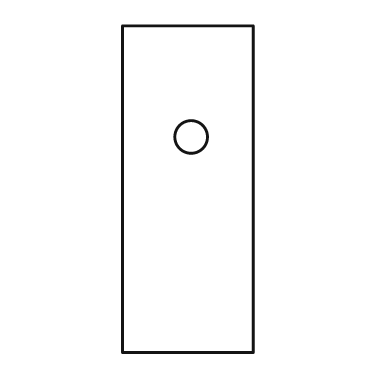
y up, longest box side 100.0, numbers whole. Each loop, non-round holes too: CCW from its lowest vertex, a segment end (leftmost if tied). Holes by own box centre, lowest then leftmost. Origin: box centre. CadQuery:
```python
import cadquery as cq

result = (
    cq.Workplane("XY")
    .moveTo(-20.0, -50.0)
    .lineTo(20.0, -50.0)
    .lineTo(20.0, 50.0)
    .lineTo(-20.0, 50.0)
    .close()
    .moveTo(1.0, 16.0)
    .circle(5.0)
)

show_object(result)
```